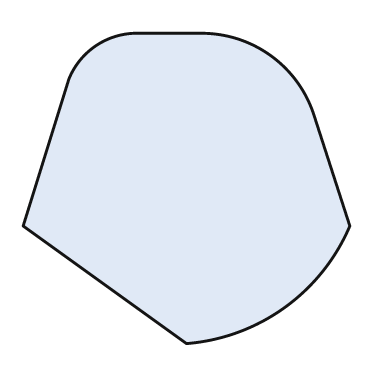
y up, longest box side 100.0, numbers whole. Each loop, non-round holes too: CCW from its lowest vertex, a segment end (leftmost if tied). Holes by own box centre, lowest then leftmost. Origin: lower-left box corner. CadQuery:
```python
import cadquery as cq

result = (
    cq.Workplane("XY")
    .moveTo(50.0, 0.0)
    .threePointArc((80.0, 11.0), (100.0, 36.0))
    .lineTo(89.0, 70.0)
    .threePointArc((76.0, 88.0), (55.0, 95.0))
    .lineTo(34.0, 95.0)
    .threePointArc((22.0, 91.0), (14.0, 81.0))
    .lineTo(0.0, 36.0)
    .close()
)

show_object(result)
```